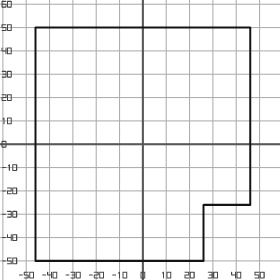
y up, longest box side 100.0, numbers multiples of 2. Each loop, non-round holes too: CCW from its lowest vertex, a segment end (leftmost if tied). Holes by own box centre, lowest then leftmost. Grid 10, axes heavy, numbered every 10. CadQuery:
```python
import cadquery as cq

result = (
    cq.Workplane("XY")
    .moveTo(-46.0, -50.0)
    .lineTo(26.0, -50.0)
    .lineTo(26.0, -26.0)
    .lineTo(46.0, -26.0)
    .lineTo(46.0, 50.0)
    .lineTo(-46.0, 50.0)
    .close()
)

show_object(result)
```